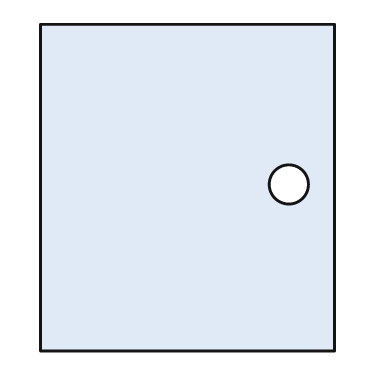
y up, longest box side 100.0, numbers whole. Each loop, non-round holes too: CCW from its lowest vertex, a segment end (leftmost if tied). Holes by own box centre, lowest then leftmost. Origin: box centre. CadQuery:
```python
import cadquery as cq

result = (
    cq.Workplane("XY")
    .moveTo(-45.0, -50.0)
    .lineTo(45.0, -50.0)
    .lineTo(45.0, 50.0)
    .lineTo(-45.0, 50.0)
    .close()
    .moveTo(31.0, 1.0)
    .circle(6.0)
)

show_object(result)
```